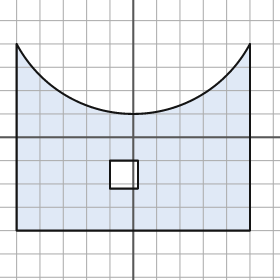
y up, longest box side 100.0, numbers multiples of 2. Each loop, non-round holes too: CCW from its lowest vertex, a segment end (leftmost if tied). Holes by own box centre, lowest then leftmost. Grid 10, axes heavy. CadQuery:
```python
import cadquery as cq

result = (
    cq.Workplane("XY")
    .moveTo(-50.0, -40.0)
    .lineTo(50.0, -40.0)
    .lineTo(50.0, 40.0)
    .threePointArc((0.0, 10.0), (-50.0, 40.0))
    .close()
    .moveTo(-10.0, -22.0)
    .lineTo(2.0, -22.0)
    .lineTo(2.0, -10.0)
    .lineTo(-10.0, -10.0)
    .close()
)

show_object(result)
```